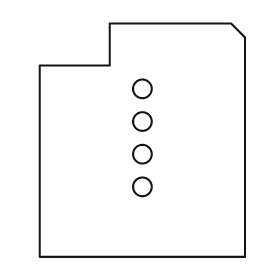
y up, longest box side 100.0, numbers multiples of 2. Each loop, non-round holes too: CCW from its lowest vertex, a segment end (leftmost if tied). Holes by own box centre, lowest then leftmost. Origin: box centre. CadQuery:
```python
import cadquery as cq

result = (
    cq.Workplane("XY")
    .moveTo(-44.0, -50.0)
    .lineTo(44.0, -50.0)
    .lineTo(44.0, 44.0)
    .lineTo(38.0, 50.0)
    .lineTo(-14.0, 50.0)
    .lineTo(-14.0, 32.0)
    .lineTo(-44.0, 32.0)
    .close()
    .moveTo(0.0, -20.0)
    .circle(4.0)
    .moveTo(0.0, -6.0)
    .circle(4.0)
    .moveTo(0.0, 8.0)
    .circle(4.0)
    .moveTo(0.0, 22.0)
    .circle(4.0)
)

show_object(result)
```